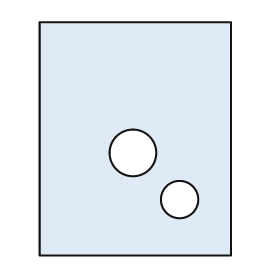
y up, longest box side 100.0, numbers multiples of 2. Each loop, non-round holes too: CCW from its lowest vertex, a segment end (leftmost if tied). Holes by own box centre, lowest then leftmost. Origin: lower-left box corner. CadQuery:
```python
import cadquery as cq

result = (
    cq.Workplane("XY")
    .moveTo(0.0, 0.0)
    .lineTo(82.0, 0.0)
    .lineTo(82.0, 100.0)
    .lineTo(0.0, 100.0)
    .close()
    .moveTo(60.0, 24.0)
    .circle(8.0)
    .moveTo(40.0, 44.0)
    .circle(10.0)
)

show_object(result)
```